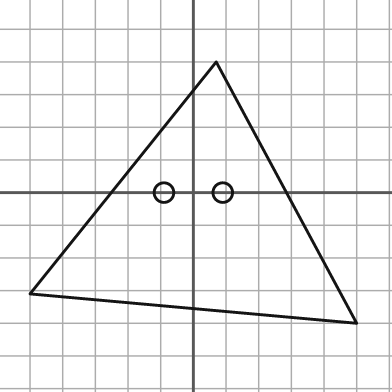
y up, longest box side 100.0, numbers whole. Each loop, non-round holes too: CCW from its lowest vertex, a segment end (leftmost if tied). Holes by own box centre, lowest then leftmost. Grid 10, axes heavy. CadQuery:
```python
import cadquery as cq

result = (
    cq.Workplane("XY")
    .moveTo(50.0, -40.0)
    .lineTo(7.0, 40.0)
    .lineTo(-50.0, -31.0)
    .close()
    .moveTo(-9.0, 0.0)
    .circle(3.0)
    .moveTo(9.0, 0.0)
    .circle(3.0)
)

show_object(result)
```